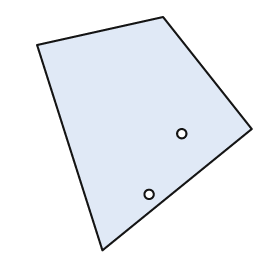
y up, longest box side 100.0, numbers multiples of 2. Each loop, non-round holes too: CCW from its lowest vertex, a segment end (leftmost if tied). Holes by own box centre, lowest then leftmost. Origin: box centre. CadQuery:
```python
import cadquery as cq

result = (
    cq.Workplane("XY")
    .moveTo(-18.0, -50.0)
    .lineTo(46.0, 2.0)
    .lineTo(8.0, 50.0)
    .lineTo(-46.0, 38.0)
    .close()
    .moveTo(2.0, -26.0)
    .circle(2.0)
    .moveTo(16.0, 0.0)
    .circle(2.0)
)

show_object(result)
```